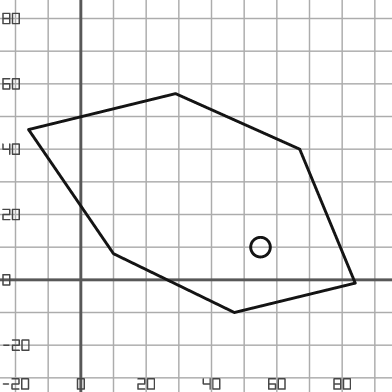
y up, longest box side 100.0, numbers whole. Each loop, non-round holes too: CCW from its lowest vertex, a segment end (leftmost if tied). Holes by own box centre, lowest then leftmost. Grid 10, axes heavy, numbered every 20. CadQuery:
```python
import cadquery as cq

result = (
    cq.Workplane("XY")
    .moveTo(47.0, -10.0)
    .lineTo(84.0, -1.0)
    .lineTo(67.0, 40.0)
    .lineTo(29.0, 57.0)
    .lineTo(-16.0, 46.0)
    .lineTo(10.0, 8.0)
    .close()
    .moveTo(55.0, 10.0)
    .circle(3.0)
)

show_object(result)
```